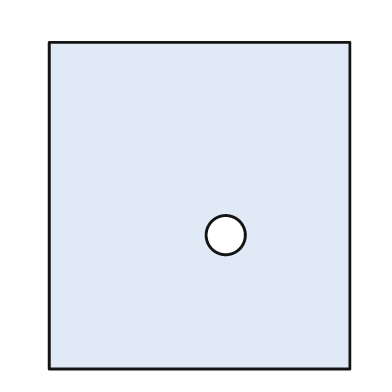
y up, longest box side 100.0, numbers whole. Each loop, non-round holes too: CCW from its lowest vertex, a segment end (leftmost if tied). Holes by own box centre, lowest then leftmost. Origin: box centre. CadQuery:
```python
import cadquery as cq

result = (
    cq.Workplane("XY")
    .moveTo(-46.0, -50.0)
    .lineTo(46.0, -50.0)
    .lineTo(46.0, 50.0)
    .lineTo(-46.0, 50.0)
    .close()
    .moveTo(8.0, -9.0)
    .circle(6.0)
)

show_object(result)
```